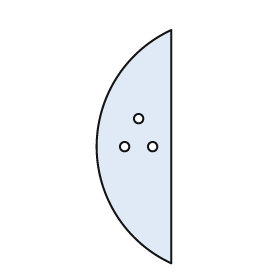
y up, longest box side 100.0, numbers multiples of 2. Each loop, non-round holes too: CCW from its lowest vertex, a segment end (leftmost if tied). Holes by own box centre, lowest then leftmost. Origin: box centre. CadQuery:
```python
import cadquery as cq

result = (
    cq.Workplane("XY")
    .moveTo(16.0, -50.0)
    .lineTo(16.0, 50.0)
    .threePointArc((-16.0, 0.0), (16.0, -50.0))
    .close()
    .moveTo(-4.0, 0.0)
    .circle(2.0)
    .moveTo(8.0, 0.0)
    .circle(2.0)
    .moveTo(2.0, 12.0)
    .circle(2.0)
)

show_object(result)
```